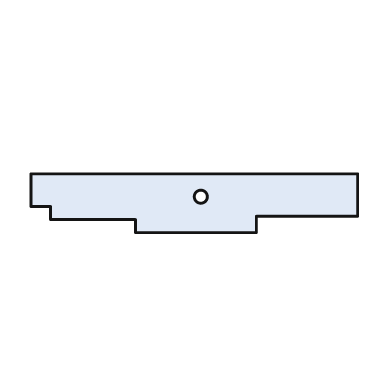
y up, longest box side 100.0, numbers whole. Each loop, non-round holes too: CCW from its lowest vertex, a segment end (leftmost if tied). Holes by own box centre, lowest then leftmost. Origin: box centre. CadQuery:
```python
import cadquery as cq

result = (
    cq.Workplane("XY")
    .moveTo(-18.0, -9.0)
    .lineTo(19.0, -9.0)
    .lineTo(19.0, -4.0)
    .lineTo(50.0, -4.0)
    .lineTo(50.0, 9.0)
    .lineTo(-50.0, 9.0)
    .lineTo(-50.0, -1.0)
    .lineTo(-44.0, -1.0)
    .lineTo(-44.0, -5.0)
    .lineTo(-18.0, -5.0)
    .close()
    .moveTo(2.0, 2.0)
    .circle(2.0)
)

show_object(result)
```